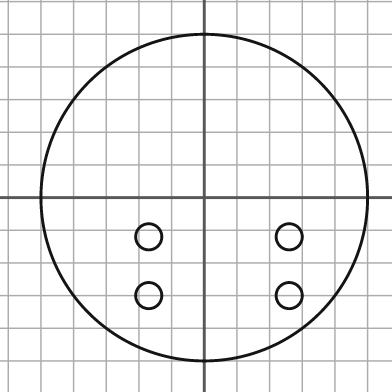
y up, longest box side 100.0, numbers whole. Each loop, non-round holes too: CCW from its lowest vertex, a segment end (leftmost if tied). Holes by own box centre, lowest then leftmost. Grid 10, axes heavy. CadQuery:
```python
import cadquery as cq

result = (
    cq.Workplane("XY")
    .moveTo(0.0, 0.0)
    .circle(50.0)
    .moveTo(-17.0, -30.0)
    .circle(4.0)
    .moveTo(26.0, -30.0)
    .circle(4.0)
    .moveTo(-17.0, -12.0)
    .circle(4.0)
    .moveTo(26.0, -12.0)
    .circle(4.0)
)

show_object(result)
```